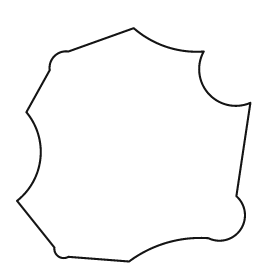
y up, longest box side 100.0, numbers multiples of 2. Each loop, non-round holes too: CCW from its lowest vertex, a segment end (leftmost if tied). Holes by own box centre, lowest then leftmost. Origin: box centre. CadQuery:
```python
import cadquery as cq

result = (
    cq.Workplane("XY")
    .moveTo(-2.0, -50.0)
    .threePointArc((14.0, -42.0), (32.0, -40.0))
    .threePointArc((46.0, -36.0), (44.0, -22.0))
    .lineTo(50.0, 18.0)
    .threePointArc((32.0, 22.0), (30.0, 40.0))
    .threePointArc((14.0, 42.0), (0.0, 50.0))
    .lineTo(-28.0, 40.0)
    .threePointArc((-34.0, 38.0), (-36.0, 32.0))
    .lineTo(-46.0, 14.0)
    .threePointArc((-40.0, -6.0), (-50.0, -24.0))
    .lineTo(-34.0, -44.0)
    .threePointArc((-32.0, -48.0), (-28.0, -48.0))
    .close()
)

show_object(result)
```